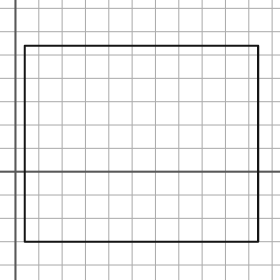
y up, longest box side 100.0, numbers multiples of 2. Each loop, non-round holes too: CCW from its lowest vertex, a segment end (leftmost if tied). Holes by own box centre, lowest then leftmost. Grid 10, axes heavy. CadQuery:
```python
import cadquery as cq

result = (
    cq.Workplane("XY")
    .moveTo(4.0, -30.0)
    .lineTo(104.0, -30.0)
    .lineTo(104.0, 54.0)
    .lineTo(4.0, 54.0)
    .close()
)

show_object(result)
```